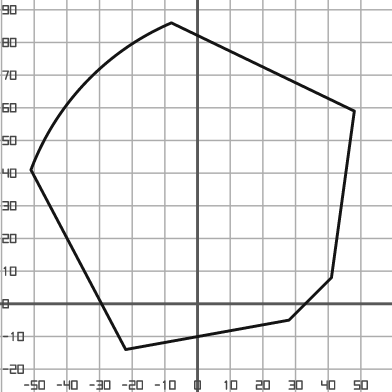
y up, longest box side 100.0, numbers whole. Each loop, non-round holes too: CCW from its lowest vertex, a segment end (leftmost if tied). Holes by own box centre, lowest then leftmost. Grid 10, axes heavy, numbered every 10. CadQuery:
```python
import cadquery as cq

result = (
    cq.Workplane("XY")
    .moveTo(-22.0, -14.0)
    .lineTo(28.0, -5.0)
    .lineTo(41.0, 8.0)
    .lineTo(48.0, 59.0)
    .lineTo(-8.0, 86.0)
    .threePointArc((-34.0, 68.0), (-51.0, 41.0))
    .close()
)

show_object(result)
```